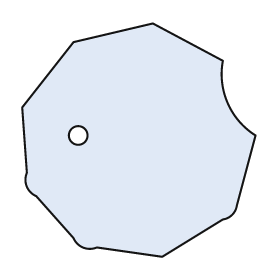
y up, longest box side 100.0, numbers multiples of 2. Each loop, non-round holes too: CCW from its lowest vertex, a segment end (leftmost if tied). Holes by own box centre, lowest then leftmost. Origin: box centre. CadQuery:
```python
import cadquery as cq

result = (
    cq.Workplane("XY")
    .moveTo(10.0, -50.0)
    .lineTo(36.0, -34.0)
    .threePointArc((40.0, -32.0), (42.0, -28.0))
    .lineTo(50.0, 2.0)
    .threePointArc((38.0, 16.0), (36.0, 34.0))
    .lineTo(6.0, 50.0)
    .lineTo(-28.0, 42.0)
    .lineTo(-50.0, 14.0)
    .lineTo(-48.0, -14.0)
    .threePointArc((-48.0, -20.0), (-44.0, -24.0))
    .lineTo(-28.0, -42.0)
    .threePointArc((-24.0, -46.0), (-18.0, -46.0))
    .close()
    .moveTo(-26.0, 2.0)
    .circle(4.0)
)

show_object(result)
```